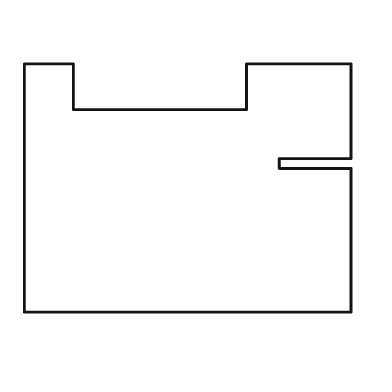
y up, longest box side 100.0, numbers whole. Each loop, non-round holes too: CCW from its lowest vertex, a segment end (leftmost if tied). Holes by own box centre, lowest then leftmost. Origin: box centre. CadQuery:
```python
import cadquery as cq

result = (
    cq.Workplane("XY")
    .moveTo(-50.0, -38.0)
    .lineTo(50.0, -38.0)
    .lineTo(50.0, 6.0)
    .lineTo(28.0, 6.0)
    .lineTo(28.0, 9.0)
    .lineTo(50.0, 9.0)
    .lineTo(50.0, 38.0)
    .lineTo(18.0, 38.0)
    .lineTo(18.0, 24.0)
    .lineTo(-35.0, 24.0)
    .lineTo(-35.0, 38.0)
    .lineTo(-50.0, 38.0)
    .close()
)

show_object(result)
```